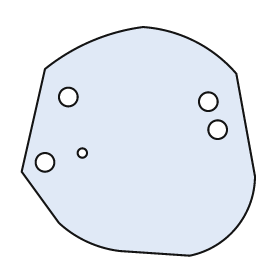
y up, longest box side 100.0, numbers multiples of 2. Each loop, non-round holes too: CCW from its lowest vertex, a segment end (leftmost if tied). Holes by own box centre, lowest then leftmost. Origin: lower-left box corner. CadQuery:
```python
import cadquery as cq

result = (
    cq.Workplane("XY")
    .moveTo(72.0, 0.0)
    .threePointArc((92.0, 12.0), (100.0, 34.0))
    .lineTo(92.0, 78.0)
    .threePointArc((74.0, 92.0), (52.0, 98.0))
    .threePointArc((30.0, 92.0), (10.0, 80.0))
    .lineTo(0.0, 36.0)
    .lineTo(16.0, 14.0)
    .threePointArc((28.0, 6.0), (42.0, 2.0))
    .close()
    .moveTo(10.0, 40.0)
    .circle(4.0)
    .moveTo(26.0, 44.0)
    .circle(2.0)
    .moveTo(84.0, 54.0)
    .circle(4.0)
    .moveTo(80.0, 66.0)
    .circle(4.0)
    .moveTo(20.0, 68.0)
    .circle(4.0)
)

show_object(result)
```